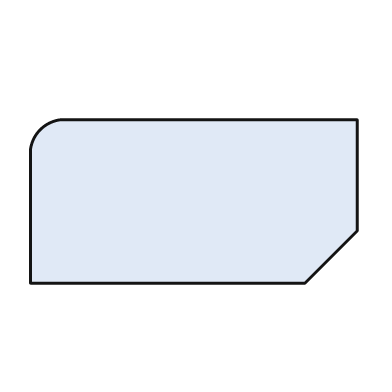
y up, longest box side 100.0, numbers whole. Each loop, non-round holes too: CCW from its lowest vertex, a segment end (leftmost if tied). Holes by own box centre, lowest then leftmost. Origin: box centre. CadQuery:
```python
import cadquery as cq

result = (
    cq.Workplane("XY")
    .moveTo(-50.0, -25.0)
    .lineTo(34.0, -25.0)
    .lineTo(50.0, -9.0)
    .lineTo(50.0, 25.0)
    .lineTo(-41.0, 25.0)
    .threePointArc((-47.0, 22.0), (-50.0, 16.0))
    .close()
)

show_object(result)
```